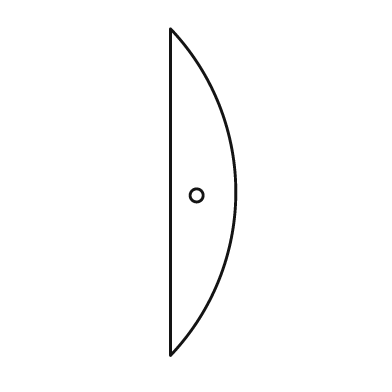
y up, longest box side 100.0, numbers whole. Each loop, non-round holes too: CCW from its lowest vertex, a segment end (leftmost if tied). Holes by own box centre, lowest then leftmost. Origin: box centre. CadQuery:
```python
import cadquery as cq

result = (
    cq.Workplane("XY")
    .moveTo(-10.0, -50.0)
    .threePointArc((10.0, 0.0), (-10.0, 50.0))
    .close()
    .moveTo(-2.0, -1.0)
    .circle(2.0)
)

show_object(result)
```